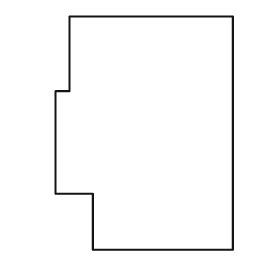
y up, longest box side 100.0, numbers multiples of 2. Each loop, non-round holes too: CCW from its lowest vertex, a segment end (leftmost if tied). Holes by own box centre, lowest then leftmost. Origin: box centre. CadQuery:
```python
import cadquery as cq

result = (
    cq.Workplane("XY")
    .moveTo(-22.0, -50.0)
    .lineTo(38.0, -50.0)
    .lineTo(38.0, 50.0)
    .lineTo(-32.0, 50.0)
    .lineTo(-32.0, 18.0)
    .lineTo(-38.0, 18.0)
    .lineTo(-38.0, -26.0)
    .lineTo(-22.0, -26.0)
    .close()
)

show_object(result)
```